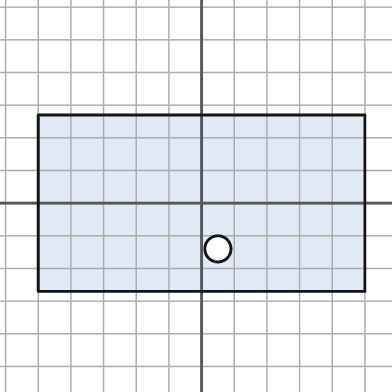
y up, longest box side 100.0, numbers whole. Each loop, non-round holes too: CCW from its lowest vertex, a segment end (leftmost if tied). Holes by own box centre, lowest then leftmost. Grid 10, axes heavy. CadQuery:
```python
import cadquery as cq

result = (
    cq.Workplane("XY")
    .moveTo(-50.0, -27.0)
    .lineTo(50.0, -27.0)
    .lineTo(50.0, 27.0)
    .lineTo(-50.0, 27.0)
    .close()
    .moveTo(5.0, -14.0)
    .circle(4.0)
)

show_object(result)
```